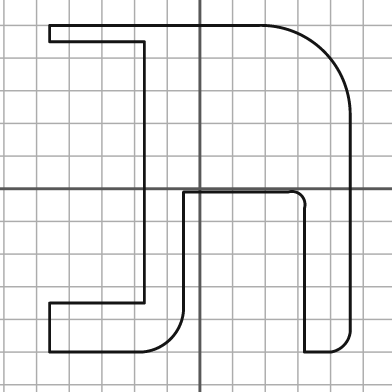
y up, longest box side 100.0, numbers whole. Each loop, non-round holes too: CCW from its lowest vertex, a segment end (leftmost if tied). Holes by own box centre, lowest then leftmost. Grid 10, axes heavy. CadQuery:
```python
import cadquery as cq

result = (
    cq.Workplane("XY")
    .moveTo(-46.0, -50.0)
    .lineTo(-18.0, -50.0)
    .threePointArc((-9.0, -46.0), (-5.0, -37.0))
    .lineTo(-5.0, -1.0)
    .lineTo(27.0, -1.0)
    .threePointArc((31.0, -2.0), (32.0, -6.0))
    .lineTo(32.0, -50.0)
    .lineTo(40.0, -50.0)
    .threePointArc((44.0, -48.0), (46.0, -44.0))
    .lineTo(46.0, 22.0)
    .threePointArc((38.0, 42.0), (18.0, 50.0))
    .lineTo(-46.0, 50.0)
    .lineTo(-46.0, 45.0)
    .lineTo(-17.0, 45.0)
    .lineTo(-17.0, -35.0)
    .lineTo(-46.0, -35.0)
    .close()
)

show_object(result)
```